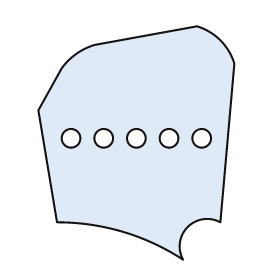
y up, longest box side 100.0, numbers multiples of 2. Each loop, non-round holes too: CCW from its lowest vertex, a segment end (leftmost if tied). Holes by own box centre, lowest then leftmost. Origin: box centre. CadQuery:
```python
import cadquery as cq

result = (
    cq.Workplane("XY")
    .moveTo(20.0, -50.0)
    .threePointArc((22.0, -36.0), (36.0, -34.0))
    .lineTo(42.0, 34.0)
    .threePointArc((36.0, 44.0), (26.0, 50.0))
    .lineTo(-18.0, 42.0)
    .threePointArc((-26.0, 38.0), (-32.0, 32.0))
    .lineTo(-42.0, 14.0)
    .lineTo(-34.0, -34.0)
    .threePointArc((-6.0, -38.0), (20.0, -50.0))
    .close()
    .moveTo(-28.0, 2.0)
    .circle(4.0)
    .moveTo(-14.0, 2.0)
    .circle(4.0)
    .moveTo(0.0, 2.0)
    .circle(4.0)
    .moveTo(14.0, 2.0)
    .circle(4.0)
    .moveTo(28.0, 2.0)
    .circle(4.0)
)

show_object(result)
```